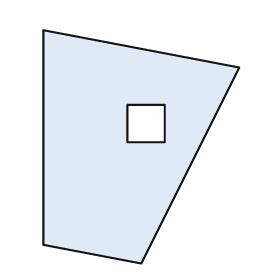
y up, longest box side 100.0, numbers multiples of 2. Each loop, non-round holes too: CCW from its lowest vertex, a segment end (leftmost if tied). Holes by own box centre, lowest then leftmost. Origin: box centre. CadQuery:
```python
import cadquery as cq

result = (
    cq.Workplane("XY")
    .moveTo(0.0, -50.0)
    .lineTo(42.0, 34.0)
    .lineTo(-42.0, 50.0)
    .lineTo(-42.0, -42.0)
    .close()
    .moveTo(-6.0, 2.0)
    .lineTo(10.0, 2.0)
    .lineTo(10.0, 18.0)
    .lineTo(-6.0, 18.0)
    .close()
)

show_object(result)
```